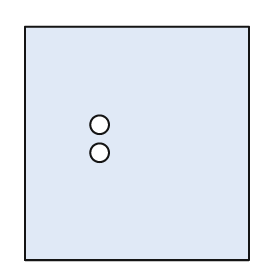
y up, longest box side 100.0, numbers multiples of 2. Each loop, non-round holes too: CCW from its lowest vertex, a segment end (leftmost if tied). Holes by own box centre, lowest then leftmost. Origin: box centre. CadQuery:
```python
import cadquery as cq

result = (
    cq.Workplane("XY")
    .moveTo(-48.0, -50.0)
    .lineTo(48.0, -50.0)
    .lineTo(48.0, 50.0)
    .lineTo(-48.0, 50.0)
    .close()
    .moveTo(-16.0, -4.0)
    .circle(4.0)
    .moveTo(-16.0, 8.0)
    .circle(4.0)
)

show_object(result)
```